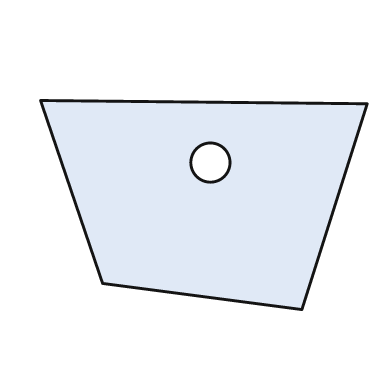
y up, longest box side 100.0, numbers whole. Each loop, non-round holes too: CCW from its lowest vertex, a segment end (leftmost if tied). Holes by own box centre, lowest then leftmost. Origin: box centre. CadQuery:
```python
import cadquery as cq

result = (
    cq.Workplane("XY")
    .moveTo(30.0, -32.0)
    .lineTo(50.0, 31.0)
    .lineTo(-50.0, 32.0)
    .lineTo(-31.0, -24.0)
    .close()
    .moveTo(2.0, 13.0)
    .circle(6.0)
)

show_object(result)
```